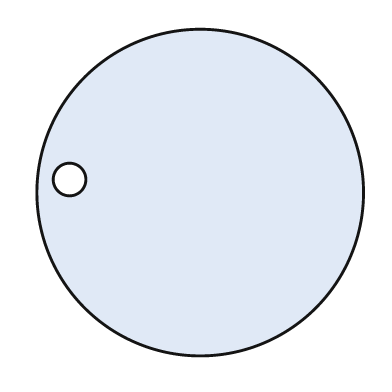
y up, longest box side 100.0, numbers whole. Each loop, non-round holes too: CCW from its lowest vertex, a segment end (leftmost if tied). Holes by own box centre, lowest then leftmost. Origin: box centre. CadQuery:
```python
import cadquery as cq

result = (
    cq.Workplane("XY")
    .moveTo(0.0, 0.0)
    .circle(50.0)
    .moveTo(-40.0, 4.0)
    .circle(5.0)
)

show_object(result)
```